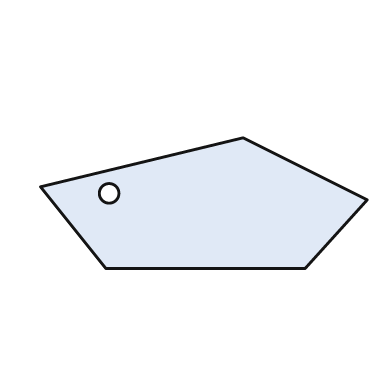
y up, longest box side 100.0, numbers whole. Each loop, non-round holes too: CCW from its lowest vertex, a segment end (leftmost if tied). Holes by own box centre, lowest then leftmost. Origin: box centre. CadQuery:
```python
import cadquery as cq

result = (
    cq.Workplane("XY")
    .moveTo(-30.0, -20.0)
    .lineTo(31.0, -20.0)
    .lineTo(50.0, 1.0)
    .lineTo(12.0, 20.0)
    .lineTo(-50.0, 5.0)
    .close()
    .moveTo(-29.0, 3.0)
    .circle(3.0)
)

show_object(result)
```